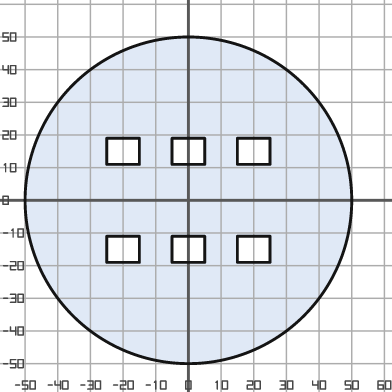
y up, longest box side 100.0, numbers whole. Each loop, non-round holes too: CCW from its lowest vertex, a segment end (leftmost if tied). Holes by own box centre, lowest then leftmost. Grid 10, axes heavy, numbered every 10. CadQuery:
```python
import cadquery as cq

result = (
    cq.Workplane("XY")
    .moveTo(0.0, 0.0)
    .circle(50.0)
    .moveTo(-25.0, -19.0)
    .lineTo(-15.0, -19.0)
    .lineTo(-15.0, -11.0)
    .lineTo(-25.0, -11.0)
    .close()
    .moveTo(-5.0, -19.0)
    .lineTo(5.0, -19.0)
    .lineTo(5.0, -11.0)
    .lineTo(-5.0, -11.0)
    .close()
    .moveTo(15.0, -19.0)
    .lineTo(25.0, -19.0)
    .lineTo(25.0, -11.0)
    .lineTo(15.0, -11.0)
    .close()
    .moveTo(-25.0, 11.0)
    .lineTo(-15.0, 11.0)
    .lineTo(-15.0, 19.0)
    .lineTo(-25.0, 19.0)
    .close()
    .moveTo(-5.0, 11.0)
    .lineTo(5.0, 11.0)
    .lineTo(5.0, 19.0)
    .lineTo(-5.0, 19.0)
    .close()
    .moveTo(15.0, 11.0)
    .lineTo(25.0, 11.0)
    .lineTo(25.0, 19.0)
    .lineTo(15.0, 19.0)
    .close()
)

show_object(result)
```